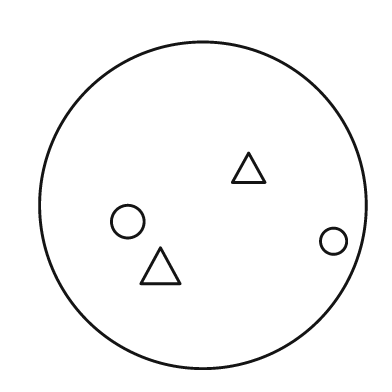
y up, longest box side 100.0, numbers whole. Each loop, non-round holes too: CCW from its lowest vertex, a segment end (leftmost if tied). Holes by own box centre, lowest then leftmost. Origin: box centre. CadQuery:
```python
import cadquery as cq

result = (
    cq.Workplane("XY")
    .moveTo(0.0, 0.0)
    .circle(50.0)
    .moveTo(-19.0, -24.0)
    .lineTo(-7.0, -24.0)
    .lineTo(-13.0, -13.0)
    .close()
    .moveTo(40.0, -11.0)
    .circle(4.0)
    .moveTo(-23.0, -5.0)
    .circle(5.0)
    .moveTo(9.0, 7.0)
    .lineTo(19.0, 7.0)
    .lineTo(14.0, 16.0)
    .close()
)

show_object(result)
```